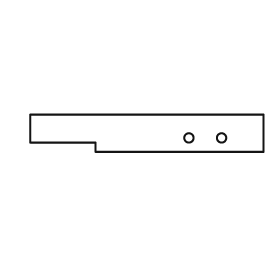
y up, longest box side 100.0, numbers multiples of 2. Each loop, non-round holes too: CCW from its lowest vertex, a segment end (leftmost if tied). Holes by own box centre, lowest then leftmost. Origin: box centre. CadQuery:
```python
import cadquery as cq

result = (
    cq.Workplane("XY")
    .moveTo(-22.0, -8.0)
    .lineTo(50.0, -8.0)
    .lineTo(50.0, 8.0)
    .lineTo(-50.0, 8.0)
    .lineTo(-50.0, -4.0)
    .lineTo(-22.0, -4.0)
    .close()
    .moveTo(18.0, -2.0)
    .circle(2.0)
    .moveTo(32.0, -2.0)
    .circle(2.0)
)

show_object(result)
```